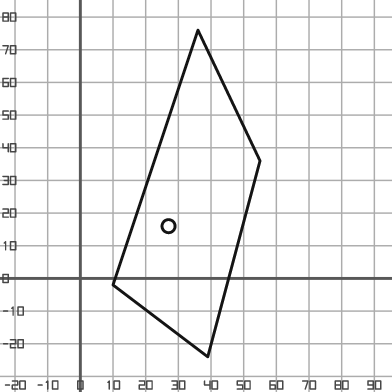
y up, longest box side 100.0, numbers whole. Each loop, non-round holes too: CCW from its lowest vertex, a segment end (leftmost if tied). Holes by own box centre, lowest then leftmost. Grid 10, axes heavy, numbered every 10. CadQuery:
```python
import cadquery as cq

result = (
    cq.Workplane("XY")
    .moveTo(39.0, -24.0)
    .lineTo(55.0, 36.0)
    .lineTo(36.0, 76.0)
    .lineTo(10.0, -2.0)
    .close()
    .moveTo(27.0, 16.0)
    .circle(2.0)
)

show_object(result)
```